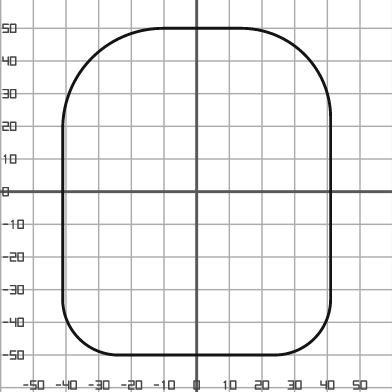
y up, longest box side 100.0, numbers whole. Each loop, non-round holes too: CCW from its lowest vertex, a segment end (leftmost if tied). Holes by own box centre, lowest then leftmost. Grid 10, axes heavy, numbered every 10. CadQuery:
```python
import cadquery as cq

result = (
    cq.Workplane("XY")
    .moveTo(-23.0, -50.0)
    .lineTo(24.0, -50.0)
    .threePointArc((36.0, -45.0), (41.0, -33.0))
    .lineTo(41.0, 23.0)
    .threePointArc((33.0, 42.0), (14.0, 50.0))
    .lineTo(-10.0, 50.0)
    .threePointArc((-32.0, 41.0), (-41.0, 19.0))
    .lineTo(-41.0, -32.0)
    .threePointArc((-36.0, -45.0), (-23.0, -50.0))
    .close()
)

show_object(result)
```